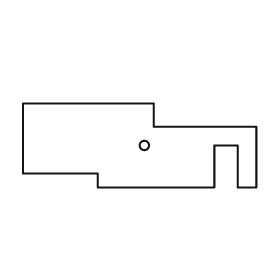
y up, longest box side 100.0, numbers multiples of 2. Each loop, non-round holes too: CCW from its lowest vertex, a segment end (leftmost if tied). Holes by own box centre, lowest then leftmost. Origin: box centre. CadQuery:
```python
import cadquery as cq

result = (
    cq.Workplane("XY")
    .moveTo(-18.0, -18.0)
    .lineTo(32.0, -18.0)
    .lineTo(32.0, 0.0)
    .lineTo(42.0, 0.0)
    .lineTo(42.0, -18.0)
    .lineTo(50.0, -18.0)
    .lineTo(50.0, 8.0)
    .lineTo(6.0, 8.0)
    .lineTo(6.0, 18.0)
    .lineTo(-50.0, 18.0)
    .lineTo(-50.0, -12.0)
    .lineTo(-18.0, -12.0)
    .close()
    .moveTo(2.0, 0.0)
    .circle(2.0)
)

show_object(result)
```